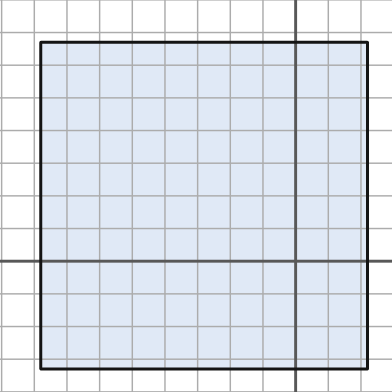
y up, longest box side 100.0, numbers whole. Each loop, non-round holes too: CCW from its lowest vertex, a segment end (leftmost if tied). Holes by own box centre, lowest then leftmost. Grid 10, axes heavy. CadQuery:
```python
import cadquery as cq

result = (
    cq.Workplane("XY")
    .moveTo(-78.0, -33.0)
    .lineTo(22.0, -33.0)
    .lineTo(22.0, 67.0)
    .lineTo(-78.0, 67.0)
    .close()
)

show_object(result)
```